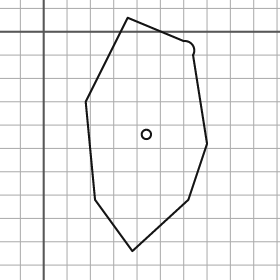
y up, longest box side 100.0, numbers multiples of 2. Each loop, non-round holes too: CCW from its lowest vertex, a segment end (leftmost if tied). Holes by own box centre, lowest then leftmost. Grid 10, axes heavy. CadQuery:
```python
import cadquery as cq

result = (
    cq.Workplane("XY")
    .moveTo(38.0, -94.0)
    .lineTo(62.0, -72.0)
    .lineTo(70.0, -48.0)
    .lineTo(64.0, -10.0)
    .threePointArc((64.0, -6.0), (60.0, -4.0))
    .lineTo(36.0, 6.0)
    .lineTo(18.0, -30.0)
    .lineTo(22.0, -72.0)
    .close()
    .moveTo(44.0, -44.0)
    .circle(2.0)
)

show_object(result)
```